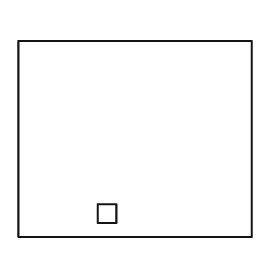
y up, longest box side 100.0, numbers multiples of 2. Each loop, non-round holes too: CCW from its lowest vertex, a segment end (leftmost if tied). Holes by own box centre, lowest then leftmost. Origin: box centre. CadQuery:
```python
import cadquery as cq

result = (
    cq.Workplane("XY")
    .moveTo(-50.0, -42.0)
    .lineTo(50.0, -42.0)
    .lineTo(50.0, 42.0)
    .lineTo(-50.0, 42.0)
    .close()
    .moveTo(-16.0, -36.0)
    .lineTo(-8.0, -36.0)
    .lineTo(-8.0, -28.0)
    .lineTo(-16.0, -28.0)
    .close()
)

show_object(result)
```